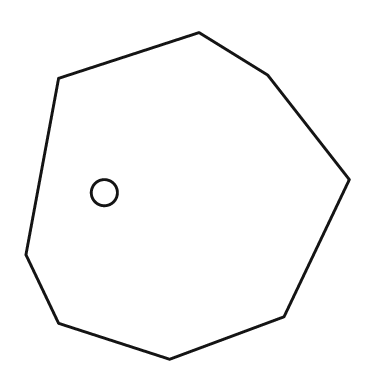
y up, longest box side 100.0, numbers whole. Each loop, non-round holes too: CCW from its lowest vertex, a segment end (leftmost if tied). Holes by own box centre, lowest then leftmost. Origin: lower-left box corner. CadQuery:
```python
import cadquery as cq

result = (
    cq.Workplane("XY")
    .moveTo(44.0, 0.0)
    .lineTo(79.0, 13.0)
    .lineTo(99.0, 55.0)
    .lineTo(74.0, 87.0)
    .lineTo(53.0, 100.0)
    .lineTo(10.0, 86.0)
    .lineTo(0.0, 32.0)
    .lineTo(10.0, 11.0)
    .close()
    .moveTo(24.0, 51.0)
    .circle(4.0)
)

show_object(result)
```